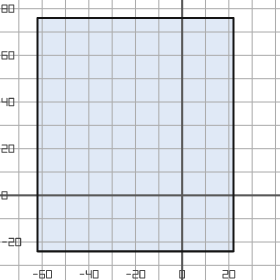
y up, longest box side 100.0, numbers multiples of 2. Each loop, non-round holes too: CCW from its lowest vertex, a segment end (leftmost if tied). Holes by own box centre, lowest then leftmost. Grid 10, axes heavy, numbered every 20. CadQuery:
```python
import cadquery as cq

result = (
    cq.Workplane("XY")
    .moveTo(-62.0, -24.0)
    .lineTo(22.0, -24.0)
    .lineTo(22.0, 76.0)
    .lineTo(-62.0, 76.0)
    .close()
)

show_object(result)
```